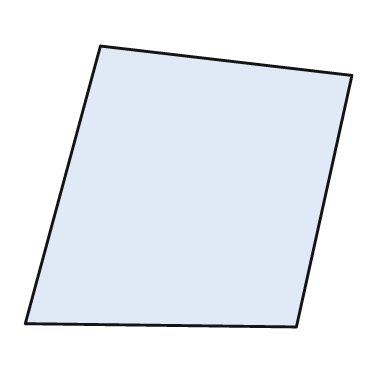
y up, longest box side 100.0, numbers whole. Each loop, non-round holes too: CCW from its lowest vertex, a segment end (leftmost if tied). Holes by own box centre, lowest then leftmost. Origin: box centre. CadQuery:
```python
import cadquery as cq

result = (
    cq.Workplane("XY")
    .moveTo(33.0, -43.0)
    .lineTo(50.0, 34.0)
    .lineTo(-27.0, 43.0)
    .lineTo(-50.0, -42.0)
    .close()
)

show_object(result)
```